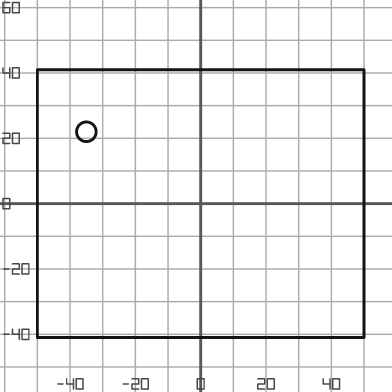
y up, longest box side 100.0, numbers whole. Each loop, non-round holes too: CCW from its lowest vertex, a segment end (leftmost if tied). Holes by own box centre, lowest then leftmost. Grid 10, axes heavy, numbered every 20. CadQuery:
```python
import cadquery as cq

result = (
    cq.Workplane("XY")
    .moveTo(-50.0, -41.0)
    .lineTo(50.0, -41.0)
    .lineTo(50.0, 41.0)
    .lineTo(-50.0, 41.0)
    .close()
    .moveTo(-35.0, 22.0)
    .circle(3.0)
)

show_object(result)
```